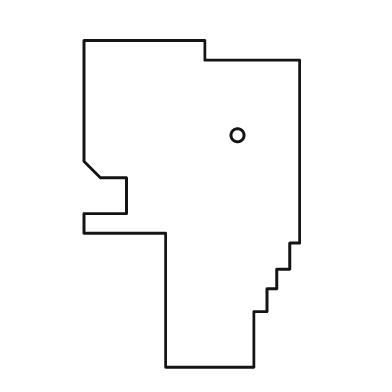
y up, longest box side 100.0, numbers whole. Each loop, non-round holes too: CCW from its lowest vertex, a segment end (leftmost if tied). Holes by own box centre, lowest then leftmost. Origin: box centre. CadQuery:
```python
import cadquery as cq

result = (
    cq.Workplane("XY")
    .moveTo(-8.0, -50.0)
    .lineTo(19.0, -50.0)
    .lineTo(19.0, -33.0)
    .lineTo(23.0, -33.0)
    .lineTo(23.0, -26.0)
    .lineTo(26.0, -26.0)
    .lineTo(26.0, -20.0)
    .lineTo(30.0, -20.0)
    .lineTo(30.0, -12.0)
    .lineTo(33.0, -12.0)
    .lineTo(33.0, 44.0)
    .lineTo(4.0, 44.0)
    .lineTo(4.0, 50.0)
    .lineTo(-33.0, 50.0)
    .lineTo(-33.0, 13.0)
    .lineTo(-28.0, 8.0)
    .lineTo(-20.0, 8.0)
    .lineTo(-20.0, -3.0)
    .lineTo(-33.0, -3.0)
    .lineTo(-33.0, -9.0)
    .lineTo(-8.0, -9.0)
    .close()
    .moveTo(14.0, 21.0)
    .circle(2.0)
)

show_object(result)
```